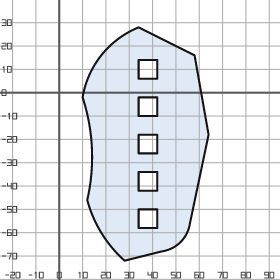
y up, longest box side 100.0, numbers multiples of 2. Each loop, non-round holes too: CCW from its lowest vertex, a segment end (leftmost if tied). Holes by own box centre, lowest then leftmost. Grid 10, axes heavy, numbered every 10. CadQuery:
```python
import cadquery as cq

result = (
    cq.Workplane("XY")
    .moveTo(28.0, -72.0)
    .lineTo(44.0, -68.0)
    .threePointArc((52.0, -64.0), (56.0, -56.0))
    .lineTo(64.0, -18.0)
    .lineTo(58.0, 16.0)
    .lineTo(34.0, 28.0)
    .threePointArc((18.0, 16.0), (10.0, -2.0))
    .threePointArc((14.0, -24.0), (12.0, -46.0))
    .threePointArc((18.0, -60.0), (28.0, -72.0))
    .close()
    .moveTo(34.0, -58.0)
    .lineTo(42.0, -58.0)
    .lineTo(42.0, -50.0)
    .lineTo(34.0, -50.0)
    .close()
    .moveTo(34.0, -42.0)
    .lineTo(42.0, -42.0)
    .lineTo(42.0, -34.0)
    .lineTo(34.0, -34.0)
    .close()
    .moveTo(34.0, -26.0)
    .lineTo(42.0, -26.0)
    .lineTo(42.0, -18.0)
    .lineTo(34.0, -18.0)
    .close()
    .moveTo(34.0, -10.0)
    .lineTo(42.0, -10.0)
    .lineTo(42.0, -2.0)
    .lineTo(34.0, -2.0)
    .close()
    .moveTo(34.0, 6.0)
    .lineTo(42.0, 6.0)
    .lineTo(42.0, 14.0)
    .lineTo(34.0, 14.0)
    .close()
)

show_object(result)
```